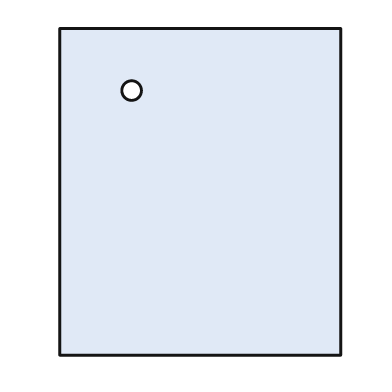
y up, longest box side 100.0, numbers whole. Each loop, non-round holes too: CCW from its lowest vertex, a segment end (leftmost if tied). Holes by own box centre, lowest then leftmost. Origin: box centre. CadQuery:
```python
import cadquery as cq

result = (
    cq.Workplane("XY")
    .moveTo(-43.0, -50.0)
    .lineTo(43.0, -50.0)
    .lineTo(43.0, 50.0)
    .lineTo(-43.0, 50.0)
    .close()
    .moveTo(-21.0, 31.0)
    .circle(3.0)
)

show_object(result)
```